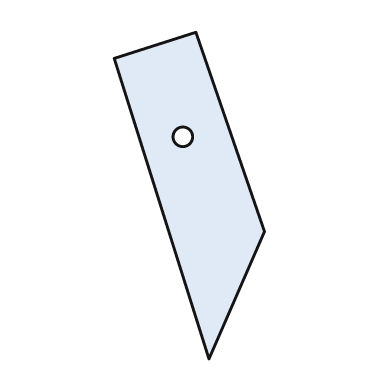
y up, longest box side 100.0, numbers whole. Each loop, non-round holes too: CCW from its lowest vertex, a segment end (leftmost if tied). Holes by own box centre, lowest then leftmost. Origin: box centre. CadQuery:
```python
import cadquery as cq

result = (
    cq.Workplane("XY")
    .moveTo(6.0, -50.0)
    .lineTo(23.0, -11.0)
    .lineTo(2.0, 50.0)
    .lineTo(-23.0, 42.0)
    .close()
    .moveTo(-2.0, 18.0)
    .circle(3.0)
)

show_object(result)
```